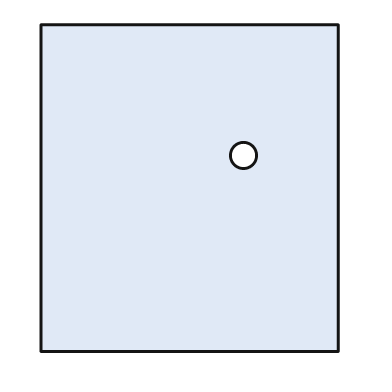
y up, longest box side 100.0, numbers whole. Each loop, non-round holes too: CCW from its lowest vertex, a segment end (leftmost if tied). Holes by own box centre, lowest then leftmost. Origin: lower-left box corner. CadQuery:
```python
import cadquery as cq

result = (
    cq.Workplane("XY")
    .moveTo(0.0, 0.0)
    .lineTo(91.0, 0.0)
    .lineTo(91.0, 100.0)
    .lineTo(0.0, 100.0)
    .close()
    .moveTo(62.0, 60.0)
    .circle(4.0)
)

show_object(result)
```